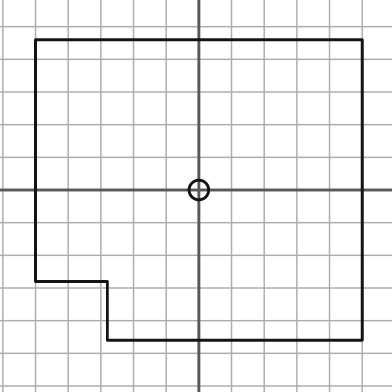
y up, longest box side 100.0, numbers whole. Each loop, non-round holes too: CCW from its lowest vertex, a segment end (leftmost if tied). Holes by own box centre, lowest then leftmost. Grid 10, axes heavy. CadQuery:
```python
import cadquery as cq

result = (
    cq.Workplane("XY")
    .moveTo(-28.0, -46.0)
    .lineTo(50.0, -46.0)
    .lineTo(50.0, 46.0)
    .lineTo(-50.0, 46.0)
    .lineTo(-50.0, -28.0)
    .lineTo(-28.0, -28.0)
    .close()
    .moveTo(0.0, 0.0)
    .circle(3.0)
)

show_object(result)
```